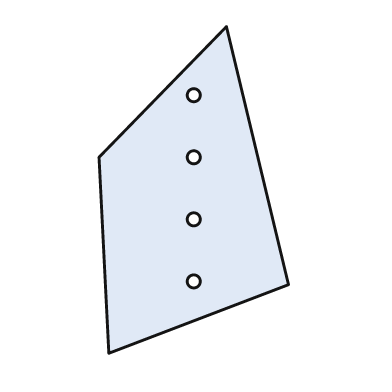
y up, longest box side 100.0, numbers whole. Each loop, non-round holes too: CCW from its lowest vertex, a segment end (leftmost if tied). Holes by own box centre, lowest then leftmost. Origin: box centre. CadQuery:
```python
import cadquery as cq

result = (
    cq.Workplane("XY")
    .moveTo(-26.0, -50.0)
    .lineTo(29.0, -29.0)
    .lineTo(10.0, 50.0)
    .lineTo(-29.0, 10.0)
    .close()
    .moveTo(0.0, -28.0)
    .circle(2.0)
    .moveTo(0.0, -9.0)
    .circle(2.0)
    .moveTo(0.0, 10.0)
    .circle(2.0)
    .moveTo(0.0, 29.0)
    .circle(2.0)
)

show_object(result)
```